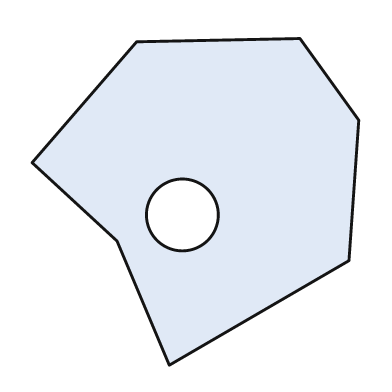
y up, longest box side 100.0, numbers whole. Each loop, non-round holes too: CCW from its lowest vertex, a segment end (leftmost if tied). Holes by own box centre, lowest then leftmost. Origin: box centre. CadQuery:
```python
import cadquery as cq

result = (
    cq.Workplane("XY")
    .moveTo(-8.0, -50.0)
    .lineTo(47.0, -18.0)
    .lineTo(50.0, 25.0)
    .lineTo(32.0, 50.0)
    .lineTo(-18.0, 49.0)
    .lineTo(-50.0, 12.0)
    .lineTo(-24.0, -12.0)
    .close()
    .moveTo(-4.0, -4.0)
    .circle(11.0)
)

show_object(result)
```